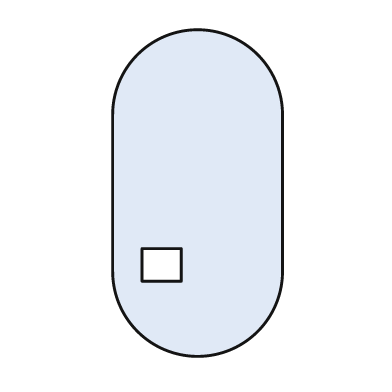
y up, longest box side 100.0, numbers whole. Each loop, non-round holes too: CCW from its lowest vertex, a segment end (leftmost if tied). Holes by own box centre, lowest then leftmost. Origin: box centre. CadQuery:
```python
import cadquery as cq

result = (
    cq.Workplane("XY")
    .moveTo(-26.0, -24.0)
    .threePointArc((0.0, -50.0), (26.0, -24.0))
    .lineTo(26.0, 24.0)
    .threePointArc((0.0, 50.0), (-26.0, 24.0))
    .close()
    .moveTo(-17.0, -27.0)
    .lineTo(-5.0, -27.0)
    .lineTo(-5.0, -17.0)
    .lineTo(-17.0, -17.0)
    .close()
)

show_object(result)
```